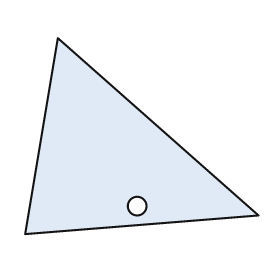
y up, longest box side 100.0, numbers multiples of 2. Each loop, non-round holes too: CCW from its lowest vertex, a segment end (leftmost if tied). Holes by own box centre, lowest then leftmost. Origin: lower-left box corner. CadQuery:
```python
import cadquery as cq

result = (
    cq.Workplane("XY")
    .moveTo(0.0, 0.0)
    .lineTo(100.0, 8.0)
    .lineTo(14.0, 84.0)
    .close()
    .moveTo(48.0, 12.0)
    .circle(4.0)
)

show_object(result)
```